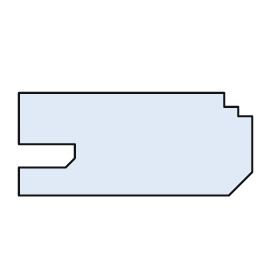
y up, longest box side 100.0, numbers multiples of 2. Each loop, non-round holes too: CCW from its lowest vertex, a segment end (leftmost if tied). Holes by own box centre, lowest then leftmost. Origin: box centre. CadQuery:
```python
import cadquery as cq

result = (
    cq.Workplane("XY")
    .moveTo(-50.0, -22.0)
    .lineTo(40.0, -22.0)
    .lineTo(50.0, -12.0)
    .lineTo(50.0, 12.0)
    .lineTo(44.0, 12.0)
    .lineTo(44.0, 16.0)
    .lineTo(38.0, 16.0)
    .lineTo(38.0, 22.0)
    .lineTo(-50.0, 22.0)
    .lineTo(-50.0, 0.0)
    .lineTo(-26.0, 0.0)
    .lineTo(-26.0, -6.0)
    .lineTo(-30.0, -10.0)
    .lineTo(-50.0, -10.0)
    .close()
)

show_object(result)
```